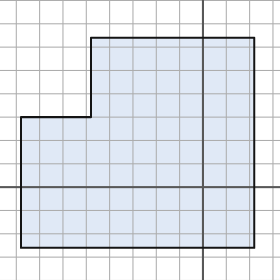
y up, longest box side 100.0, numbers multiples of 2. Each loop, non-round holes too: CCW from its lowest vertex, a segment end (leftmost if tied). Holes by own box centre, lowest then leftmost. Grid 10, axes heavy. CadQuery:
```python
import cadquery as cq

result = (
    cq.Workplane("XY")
    .moveTo(-78.0, -26.0)
    .lineTo(22.0, -26.0)
    .lineTo(22.0, 64.0)
    .lineTo(-48.0, 64.0)
    .lineTo(-48.0, 30.0)
    .lineTo(-78.0, 30.0)
    .close()
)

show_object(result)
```